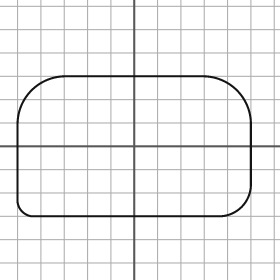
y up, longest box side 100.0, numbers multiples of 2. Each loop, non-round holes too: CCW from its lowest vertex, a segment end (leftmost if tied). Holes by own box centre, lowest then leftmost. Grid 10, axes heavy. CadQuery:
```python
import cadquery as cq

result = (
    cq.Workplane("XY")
    .moveTo(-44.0, -30.0)
    .lineTo(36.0, -30.0)
    .threePointArc((46.0, -26.0), (50.0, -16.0))
    .lineTo(50.0, 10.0)
    .threePointArc((44.0, 24.0), (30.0, 30.0))
    .lineTo(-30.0, 30.0)
    .threePointArc((-44.0, 24.0), (-50.0, 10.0))
    .lineTo(-50.0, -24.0)
    .threePointArc((-48.0, -28.0), (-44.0, -30.0))
    .close()
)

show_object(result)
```